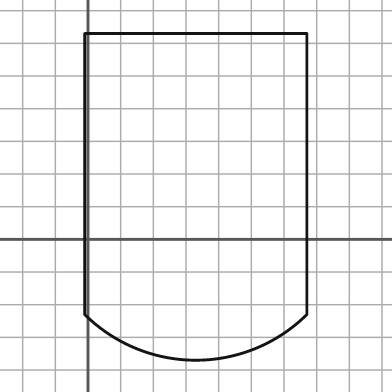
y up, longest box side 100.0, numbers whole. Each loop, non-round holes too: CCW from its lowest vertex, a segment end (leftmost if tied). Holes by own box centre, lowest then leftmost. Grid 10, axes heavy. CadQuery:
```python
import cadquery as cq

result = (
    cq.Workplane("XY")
    .moveTo(-1.0, -23.0)
    .threePointArc((33.0, -37.0), (67.0, -23.0))
    .lineTo(67.0, 63.0)
    .lineTo(-1.0, 63.0)
    .close()
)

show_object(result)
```